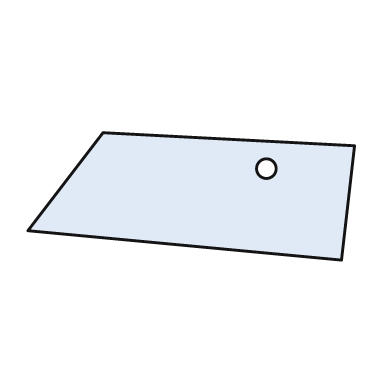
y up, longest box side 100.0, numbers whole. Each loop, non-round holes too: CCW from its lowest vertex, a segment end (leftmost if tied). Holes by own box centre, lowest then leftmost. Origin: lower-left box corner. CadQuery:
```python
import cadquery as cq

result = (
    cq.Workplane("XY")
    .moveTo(96.0, 0.0)
    .lineTo(100.0, 35.0)
    .lineTo(23.0, 39.0)
    .lineTo(0.0, 9.0)
    .close()
    .moveTo(73.0, 28.0)
    .circle(3.0)
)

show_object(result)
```